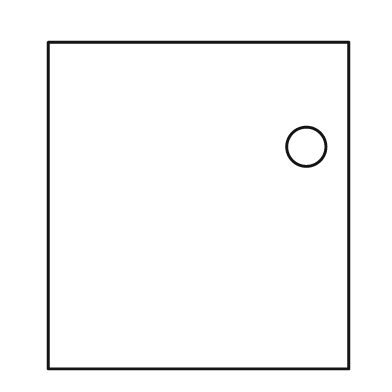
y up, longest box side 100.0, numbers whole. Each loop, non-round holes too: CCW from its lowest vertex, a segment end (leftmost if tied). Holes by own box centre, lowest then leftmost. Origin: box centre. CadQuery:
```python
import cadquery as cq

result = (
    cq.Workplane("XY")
    .moveTo(-46.0, -50.0)
    .lineTo(46.0, -50.0)
    .lineTo(46.0, 50.0)
    .lineTo(-46.0, 50.0)
    .close()
    .moveTo(33.0, 18.0)
    .circle(6.0)
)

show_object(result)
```